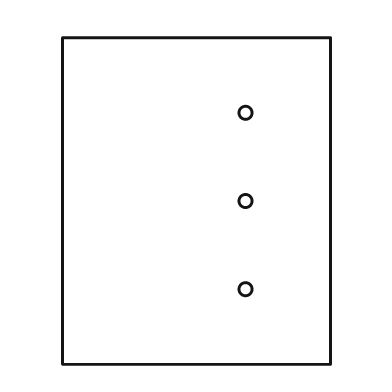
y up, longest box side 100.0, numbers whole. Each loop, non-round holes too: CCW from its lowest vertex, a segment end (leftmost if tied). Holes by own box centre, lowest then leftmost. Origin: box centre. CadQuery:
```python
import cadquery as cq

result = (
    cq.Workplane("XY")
    .moveTo(-41.0, -50.0)
    .lineTo(41.0, -50.0)
    .lineTo(41.0, 50.0)
    .lineTo(-41.0, 50.0)
    .close()
    .moveTo(15.0, -27.0)
    .circle(2.0)
    .moveTo(15.0, 0.0)
    .circle(2.0)
    .moveTo(15.0, 27.0)
    .circle(2.0)
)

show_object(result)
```